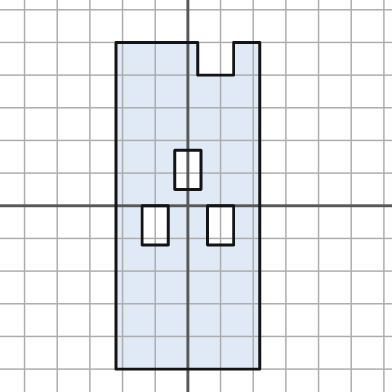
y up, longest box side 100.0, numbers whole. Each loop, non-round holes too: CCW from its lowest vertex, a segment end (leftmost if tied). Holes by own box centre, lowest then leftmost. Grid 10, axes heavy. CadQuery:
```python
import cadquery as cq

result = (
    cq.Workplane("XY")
    .moveTo(-22.0, -50.0)
    .lineTo(22.0, -50.0)
    .lineTo(22.0, 50.0)
    .lineTo(14.0, 50.0)
    .lineTo(14.0, 40.0)
    .lineTo(3.0, 40.0)
    .lineTo(3.0, 50.0)
    .lineTo(-22.0, 50.0)
    .close()
    .moveTo(-14.0, -12.0)
    .lineTo(-6.0, -12.0)
    .lineTo(-6.0, 0.0)
    .lineTo(-14.0, 0.0)
    .close()
    .moveTo(6.0, -12.0)
    .lineTo(14.0, -12.0)
    .lineTo(14.0, 0.0)
    .lineTo(6.0, 0.0)
    .close()
    .moveTo(-4.0, 5.0)
    .lineTo(4.0, 5.0)
    .lineTo(4.0, 17.0)
    .lineTo(-4.0, 17.0)
    .close()
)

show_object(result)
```